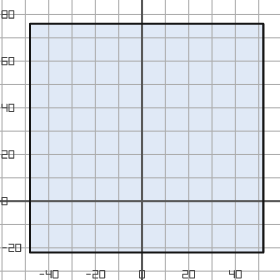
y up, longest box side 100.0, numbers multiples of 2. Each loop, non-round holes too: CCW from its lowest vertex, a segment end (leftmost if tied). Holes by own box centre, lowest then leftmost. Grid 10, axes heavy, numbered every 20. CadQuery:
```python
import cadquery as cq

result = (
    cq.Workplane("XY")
    .moveTo(-48.0, -22.0)
    .lineTo(52.0, -22.0)
    .lineTo(52.0, 76.0)
    .lineTo(-48.0, 76.0)
    .close()
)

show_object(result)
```